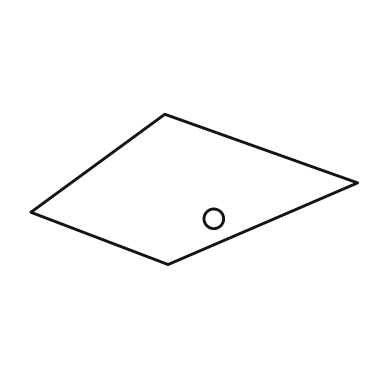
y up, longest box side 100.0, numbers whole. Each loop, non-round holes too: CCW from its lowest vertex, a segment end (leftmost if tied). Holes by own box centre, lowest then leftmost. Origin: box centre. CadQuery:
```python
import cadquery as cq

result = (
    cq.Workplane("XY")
    .moveTo(-8.0, -23.0)
    .lineTo(50.0, 2.0)
    .lineTo(-9.0, 23.0)
    .lineTo(-50.0, -7.0)
    .close()
    .moveTo(6.0, -9.0)
    .circle(3.0)
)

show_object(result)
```